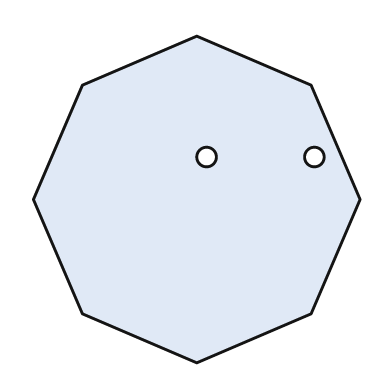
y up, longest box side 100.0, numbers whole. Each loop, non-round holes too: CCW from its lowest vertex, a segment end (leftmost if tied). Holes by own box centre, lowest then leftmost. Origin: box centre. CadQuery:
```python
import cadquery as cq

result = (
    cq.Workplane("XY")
    .moveTo(0.0, -50.0)
    .lineTo(35.0, -35.0)
    .lineTo(50.0, 0.0)
    .lineTo(35.0, 35.0)
    .lineTo(0.0, 50.0)
    .lineTo(-35.0, 35.0)
    .lineTo(-50.0, 0.0)
    .lineTo(-35.0, -35.0)
    .close()
    .moveTo(3.0, 13.0)
    .circle(3.0)
    .moveTo(36.0, 13.0)
    .circle(3.0)
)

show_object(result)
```